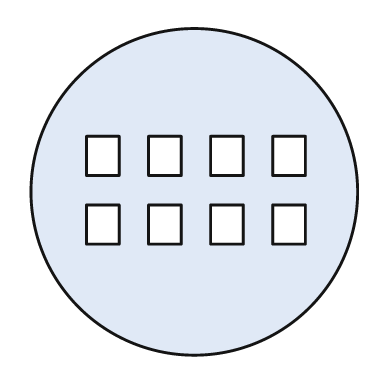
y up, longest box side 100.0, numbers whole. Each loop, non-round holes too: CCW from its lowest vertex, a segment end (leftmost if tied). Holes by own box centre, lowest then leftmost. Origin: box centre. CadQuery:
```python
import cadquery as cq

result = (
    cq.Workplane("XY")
    .moveTo(0.0, 0.0)
    .circle(50.0)
    .moveTo(-33.0, -16.0)
    .lineTo(-23.0, -16.0)
    .lineTo(-23.0, -4.0)
    .lineTo(-33.0, -4.0)
    .close()
    .moveTo(-14.0, -16.0)
    .lineTo(-4.0, -16.0)
    .lineTo(-4.0, -4.0)
    .lineTo(-14.0, -4.0)
    .close()
    .moveTo(5.0, -16.0)
    .lineTo(15.0, -16.0)
    .lineTo(15.0, -4.0)
    .lineTo(5.0, -4.0)
    .close()
    .moveTo(24.0, -16.0)
    .lineTo(34.0, -16.0)
    .lineTo(34.0, -4.0)
    .lineTo(24.0, -4.0)
    .close()
    .moveTo(-33.0, 5.0)
    .lineTo(-23.0, 5.0)
    .lineTo(-23.0, 17.0)
    .lineTo(-33.0, 17.0)
    .close()
    .moveTo(-14.0, 5.0)
    .lineTo(-4.0, 5.0)
    .lineTo(-4.0, 17.0)
    .lineTo(-14.0, 17.0)
    .close()
    .moveTo(5.0, 5.0)
    .lineTo(15.0, 5.0)
    .lineTo(15.0, 17.0)
    .lineTo(5.0, 17.0)
    .close()
    .moveTo(24.0, 5.0)
    .lineTo(34.0, 5.0)
    .lineTo(34.0, 17.0)
    .lineTo(24.0, 17.0)
    .close()
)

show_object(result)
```